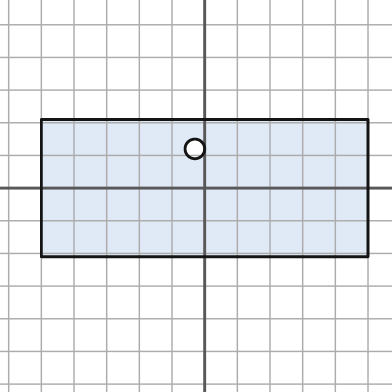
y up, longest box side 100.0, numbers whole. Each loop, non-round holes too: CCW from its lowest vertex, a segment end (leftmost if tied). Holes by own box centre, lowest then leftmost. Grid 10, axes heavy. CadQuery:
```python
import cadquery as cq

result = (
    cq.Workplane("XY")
    .moveTo(-50.0, -21.0)
    .lineTo(50.0, -21.0)
    .lineTo(50.0, 21.0)
    .lineTo(-50.0, 21.0)
    .close()
    .moveTo(-3.0, 12.0)
    .circle(3.0)
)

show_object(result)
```